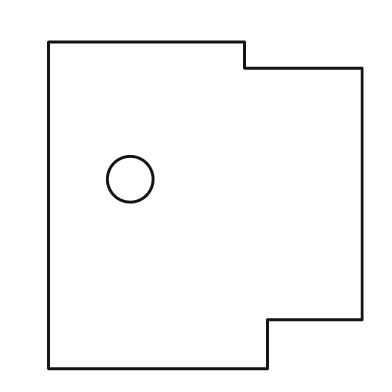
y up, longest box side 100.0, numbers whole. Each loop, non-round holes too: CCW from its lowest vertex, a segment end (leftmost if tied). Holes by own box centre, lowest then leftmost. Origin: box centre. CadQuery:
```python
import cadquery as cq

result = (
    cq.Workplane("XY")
    .moveTo(-48.0, -50.0)
    .lineTo(19.0, -50.0)
    .lineTo(19.0, -35.0)
    .lineTo(48.0, -35.0)
    .lineTo(48.0, 42.0)
    .lineTo(12.0, 42.0)
    .lineTo(12.0, 50.0)
    .lineTo(-48.0, 50.0)
    .close()
    .moveTo(-23.0, 8.0)
    .circle(7.0)
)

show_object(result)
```